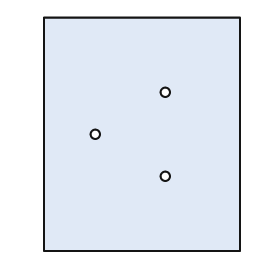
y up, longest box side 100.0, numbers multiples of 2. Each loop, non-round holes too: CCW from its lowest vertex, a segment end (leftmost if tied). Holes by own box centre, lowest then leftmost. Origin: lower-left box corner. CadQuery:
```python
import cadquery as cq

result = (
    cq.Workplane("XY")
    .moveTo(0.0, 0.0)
    .lineTo(84.0, 0.0)
    .lineTo(84.0, 100.0)
    .lineTo(0.0, 100.0)
    .close()
    .moveTo(52.0, 32.0)
    .circle(2.0)
    .moveTo(22.0, 50.0)
    .circle(2.0)
    .moveTo(52.0, 68.0)
    .circle(2.0)
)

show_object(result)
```